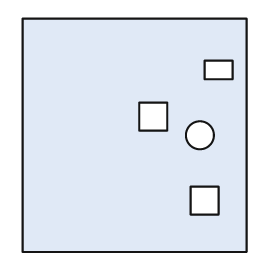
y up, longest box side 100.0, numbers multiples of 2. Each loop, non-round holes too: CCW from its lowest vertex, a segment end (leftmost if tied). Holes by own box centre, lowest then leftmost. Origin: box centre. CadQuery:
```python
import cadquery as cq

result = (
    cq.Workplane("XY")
    .moveTo(-48.0, -50.0)
    .lineTo(48.0, -50.0)
    .lineTo(48.0, 50.0)
    .lineTo(-48.0, 50.0)
    .close()
    .moveTo(24.0, -34.0)
    .lineTo(36.0, -34.0)
    .lineTo(36.0, -22.0)
    .lineTo(24.0, -22.0)
    .close()
    .moveTo(28.0, 0.0)
    .circle(6.0)
    .moveTo(2.0, 2.0)
    .lineTo(14.0, 2.0)
    .lineTo(14.0, 14.0)
    .lineTo(2.0, 14.0)
    .close()
    .moveTo(30.0, 24.0)
    .lineTo(42.0, 24.0)
    .lineTo(42.0, 32.0)
    .lineTo(30.0, 32.0)
    .close()
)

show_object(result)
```